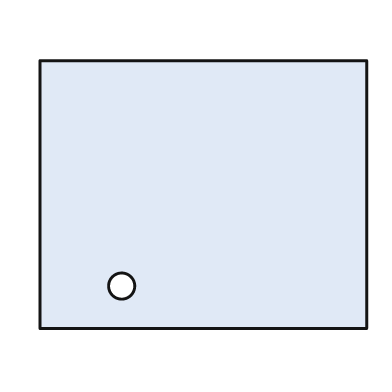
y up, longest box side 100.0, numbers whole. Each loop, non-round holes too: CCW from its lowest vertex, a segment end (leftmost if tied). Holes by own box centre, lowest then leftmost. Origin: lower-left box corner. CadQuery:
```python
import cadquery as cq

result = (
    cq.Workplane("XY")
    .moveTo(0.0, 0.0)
    .lineTo(100.0, 0.0)
    .lineTo(100.0, 82.0)
    .lineTo(0.0, 82.0)
    .close()
    .moveTo(25.0, 13.0)
    .circle(4.0)
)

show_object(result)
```